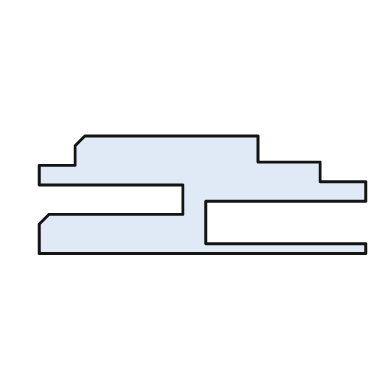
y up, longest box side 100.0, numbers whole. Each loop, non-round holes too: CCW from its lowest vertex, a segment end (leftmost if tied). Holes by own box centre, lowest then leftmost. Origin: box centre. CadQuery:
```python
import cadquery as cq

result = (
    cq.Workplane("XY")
    .moveTo(-50.0, -18.0)
    .lineTo(50.0, -18.0)
    .lineTo(50.0, -15.0)
    .lineTo(1.0, -15.0)
    .lineTo(1.0, -2.0)
    .lineTo(50.0, -2.0)
    .lineTo(50.0, 4.0)
    .lineTo(36.0, 4.0)
    .lineTo(36.0, 10.0)
    .lineTo(17.0, 10.0)
    .lineTo(17.0, 18.0)
    .lineTo(-36.0, 18.0)
    .lineTo(-39.0, 15.0)
    .lineTo(-39.0, 9.0)
    .lineTo(-50.0, 9.0)
    .lineTo(-50.0, 3.0)
    .lineTo(-6.0, 3.0)
    .lineTo(-6.0, -6.0)
    .lineTo(-47.0, -6.0)
    .lineTo(-50.0, -9.0)
    .close()
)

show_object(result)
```